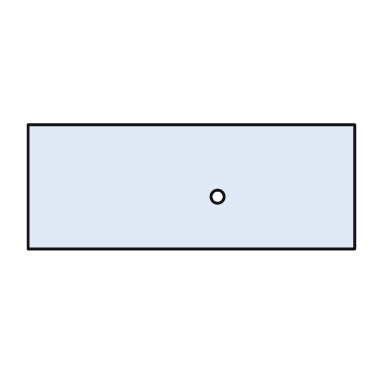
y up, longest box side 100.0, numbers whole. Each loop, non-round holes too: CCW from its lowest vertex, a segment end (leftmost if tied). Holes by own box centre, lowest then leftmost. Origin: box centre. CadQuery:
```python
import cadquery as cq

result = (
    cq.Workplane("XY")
    .moveTo(-50.0, -19.0)
    .lineTo(50.0, -19.0)
    .lineTo(50.0, 19.0)
    .lineTo(-50.0, 19.0)
    .close()
    .moveTo(8.0, -3.0)
    .circle(2.0)
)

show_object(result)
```